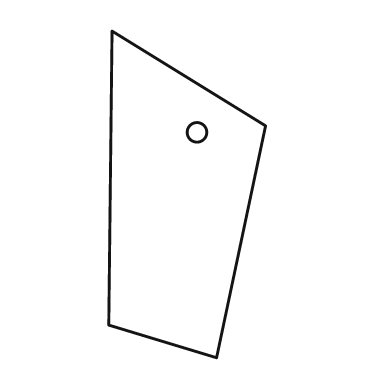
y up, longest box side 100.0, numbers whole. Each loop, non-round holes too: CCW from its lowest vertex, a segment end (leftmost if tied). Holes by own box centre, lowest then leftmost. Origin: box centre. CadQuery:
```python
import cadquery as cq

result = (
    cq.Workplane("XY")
    .moveTo(9.0, -50.0)
    .lineTo(24.0, 21.0)
    .lineTo(-23.0, 50.0)
    .lineTo(-24.0, -40.0)
    .close()
    .moveTo(3.0, 19.0)
    .circle(3.0)
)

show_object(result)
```